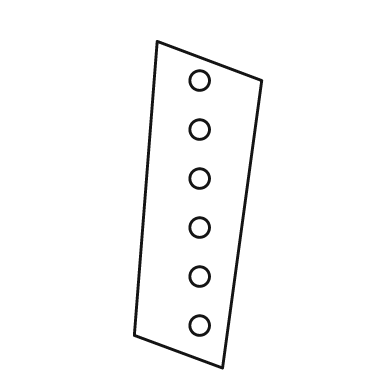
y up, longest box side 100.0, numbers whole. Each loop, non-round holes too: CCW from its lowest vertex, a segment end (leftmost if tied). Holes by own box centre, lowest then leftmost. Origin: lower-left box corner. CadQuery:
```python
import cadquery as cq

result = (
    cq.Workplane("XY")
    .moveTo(27.0, 0.0)
    .lineTo(39.0, 88.0)
    .lineTo(7.0, 100.0)
    .lineTo(0.0, 10.0)
    .close()
    .moveTo(20.0, 13.0)
    .circle(3.0)
    .moveTo(20.0, 28.0)
    .circle(3.0)
    .moveTo(20.0, 43.0)
    .circle(3.0)
    .moveTo(20.0, 58.0)
    .circle(3.0)
    .moveTo(20.0, 73.0)
    .circle(3.0)
    .moveTo(20.0, 88.0)
    .circle(3.0)
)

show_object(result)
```